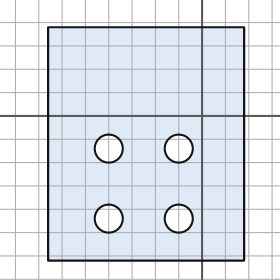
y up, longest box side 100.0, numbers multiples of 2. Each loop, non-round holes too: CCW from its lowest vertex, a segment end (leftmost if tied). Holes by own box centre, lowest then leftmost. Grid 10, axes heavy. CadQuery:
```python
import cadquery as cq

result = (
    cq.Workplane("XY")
    .moveTo(-66.0, -62.0)
    .lineTo(18.0, -62.0)
    .lineTo(18.0, 38.0)
    .lineTo(-66.0, 38.0)
    .close()
    .moveTo(-40.0, -44.0)
    .circle(6.0)
    .moveTo(-10.0, -44.0)
    .circle(6.0)
    .moveTo(-40.0, -14.0)
    .circle(6.0)
    .moveTo(-10.0, -14.0)
    .circle(6.0)
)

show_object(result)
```